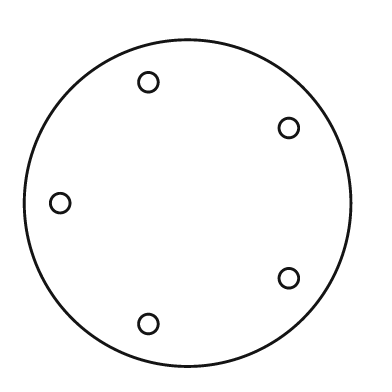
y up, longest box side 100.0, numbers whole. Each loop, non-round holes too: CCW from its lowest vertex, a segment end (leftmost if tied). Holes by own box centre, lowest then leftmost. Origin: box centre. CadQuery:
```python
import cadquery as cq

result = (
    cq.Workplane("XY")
    .moveTo(0.0, 0.0)
    .circle(50.0)
    .moveTo(-12.0, -37.0)
    .circle(3.0)
    .moveTo(31.0, -23.0)
    .circle(3.0)
    .moveTo(-39.0, 0.0)
    .circle(3.0)
    .moveTo(31.0, 23.0)
    .circle(3.0)
    .moveTo(-12.0, 37.0)
    .circle(3.0)
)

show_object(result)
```